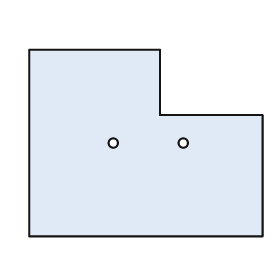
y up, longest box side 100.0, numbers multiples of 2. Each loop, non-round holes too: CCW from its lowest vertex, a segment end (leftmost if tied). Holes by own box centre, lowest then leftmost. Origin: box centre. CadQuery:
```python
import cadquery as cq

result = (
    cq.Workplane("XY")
    .moveTo(-50.0, -40.0)
    .lineTo(50.0, -40.0)
    .lineTo(50.0, 12.0)
    .lineTo(6.0, 12.0)
    .lineTo(6.0, 40.0)
    .lineTo(-50.0, 40.0)
    .close()
    .moveTo(-14.0, 0.0)
    .circle(2.0)
    .moveTo(16.0, 0.0)
    .circle(2.0)
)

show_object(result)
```